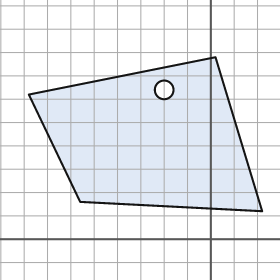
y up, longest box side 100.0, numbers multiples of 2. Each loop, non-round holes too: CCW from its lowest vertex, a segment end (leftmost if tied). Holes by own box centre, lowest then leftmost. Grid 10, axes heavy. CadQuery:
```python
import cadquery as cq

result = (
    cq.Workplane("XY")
    .moveTo(22.0, 12.0)
    .lineTo(2.0, 78.0)
    .lineTo(-78.0, 62.0)
    .lineTo(-56.0, 16.0)
    .close()
    .moveTo(-20.0, 64.0)
    .circle(4.0)
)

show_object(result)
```